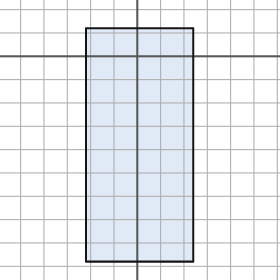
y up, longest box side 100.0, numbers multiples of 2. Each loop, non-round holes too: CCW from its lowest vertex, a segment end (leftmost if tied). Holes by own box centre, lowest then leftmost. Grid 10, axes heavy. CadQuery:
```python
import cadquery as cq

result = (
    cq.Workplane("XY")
    .moveTo(-22.0, -88.0)
    .lineTo(24.0, -88.0)
    .lineTo(24.0, 12.0)
    .lineTo(-22.0, 12.0)
    .close()
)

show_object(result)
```